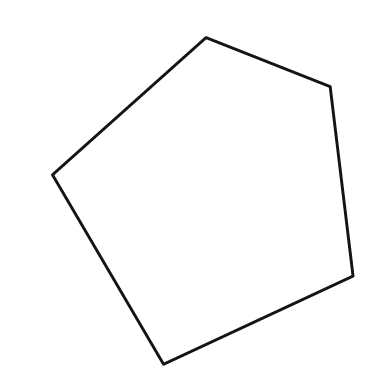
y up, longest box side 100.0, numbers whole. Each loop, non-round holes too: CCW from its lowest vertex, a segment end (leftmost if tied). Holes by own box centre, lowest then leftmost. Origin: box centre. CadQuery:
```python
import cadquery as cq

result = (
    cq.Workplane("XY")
    .moveTo(-12.0, -50.0)
    .lineTo(46.0, -23.0)
    .lineTo(39.0, 35.0)
    .lineTo(1.0, 50.0)
    .lineTo(-46.0, 8.0)
    .close()
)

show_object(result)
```